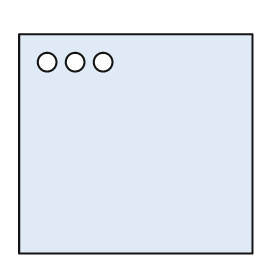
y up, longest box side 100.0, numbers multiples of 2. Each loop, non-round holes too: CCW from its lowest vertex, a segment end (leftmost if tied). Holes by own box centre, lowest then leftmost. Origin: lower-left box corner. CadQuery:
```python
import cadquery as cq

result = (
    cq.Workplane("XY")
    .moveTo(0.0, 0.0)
    .lineTo(100.0, 0.0)
    .lineTo(100.0, 94.0)
    .lineTo(0.0, 94.0)
    .close()
    .moveTo(12.0, 82.0)
    .circle(4.0)
    .moveTo(24.0, 82.0)
    .circle(4.0)
    .moveTo(36.0, 82.0)
    .circle(4.0)
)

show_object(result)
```